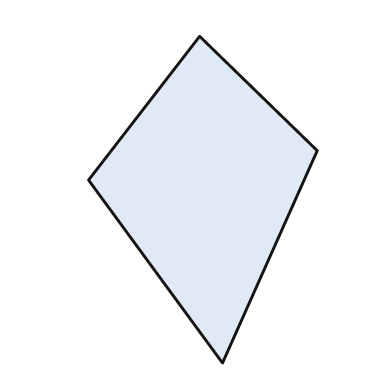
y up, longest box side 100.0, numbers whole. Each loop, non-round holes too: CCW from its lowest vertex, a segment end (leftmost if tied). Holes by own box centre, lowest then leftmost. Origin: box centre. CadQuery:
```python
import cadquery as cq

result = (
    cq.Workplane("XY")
    .moveTo(6.0, -50.0)
    .lineTo(35.0, 15.0)
    .lineTo(-1.0, 50.0)
    .lineTo(-35.0, 6.0)
    .close()
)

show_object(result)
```